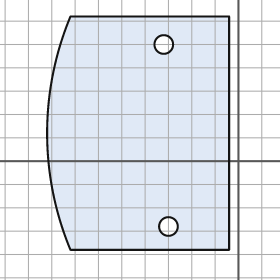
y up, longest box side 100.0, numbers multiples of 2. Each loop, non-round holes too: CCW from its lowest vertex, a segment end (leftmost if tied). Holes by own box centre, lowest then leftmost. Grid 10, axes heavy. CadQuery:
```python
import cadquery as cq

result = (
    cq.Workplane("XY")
    .moveTo(-72.0, -38.0)
    .lineTo(-4.0, -38.0)
    .lineTo(-4.0, 62.0)
    .lineTo(-72.0, 62.0)
    .threePointArc((-82.0, 12.0), (-72.0, -38.0))
    .close()
    .moveTo(-30.0, -28.0)
    .circle(4.0)
    .moveTo(-32.0, 50.0)
    .circle(4.0)
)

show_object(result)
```